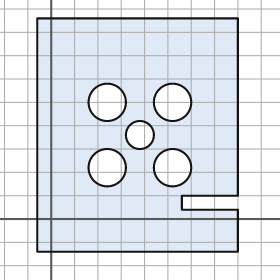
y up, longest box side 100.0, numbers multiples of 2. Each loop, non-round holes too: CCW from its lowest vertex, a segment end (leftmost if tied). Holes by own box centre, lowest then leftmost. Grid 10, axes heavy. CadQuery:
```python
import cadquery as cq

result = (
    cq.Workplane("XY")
    .moveTo(-6.0, -14.0)
    .lineTo(80.0, -14.0)
    .lineTo(80.0, 4.0)
    .lineTo(56.0, 4.0)
    .lineTo(56.0, 10.0)
    .lineTo(80.0, 10.0)
    .lineTo(80.0, 86.0)
    .lineTo(-6.0, 86.0)
    .close()
    .moveTo(24.0, 22.0)
    .circle(8.0)
    .moveTo(52.0, 22.0)
    .circle(8.0)
    .moveTo(38.0, 36.0)
    .circle(6.0)
    .moveTo(24.0, 50.0)
    .circle(8.0)
    .moveTo(52.0, 50.0)
    .circle(8.0)
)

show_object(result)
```